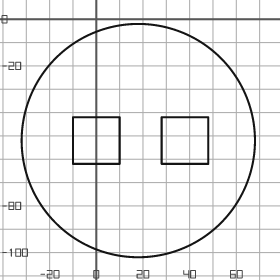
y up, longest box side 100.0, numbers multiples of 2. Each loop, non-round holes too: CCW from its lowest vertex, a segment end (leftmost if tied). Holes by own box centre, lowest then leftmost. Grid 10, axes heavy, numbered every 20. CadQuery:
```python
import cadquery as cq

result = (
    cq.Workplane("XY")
    .moveTo(18.0, -52.0)
    .circle(50.0)
    .moveTo(-10.0, -62.0)
    .lineTo(10.0, -62.0)
    .lineTo(10.0, -42.0)
    .lineTo(-10.0, -42.0)
    .close()
    .moveTo(28.0, -62.0)
    .lineTo(48.0, -62.0)
    .lineTo(48.0, -42.0)
    .lineTo(28.0, -42.0)
    .close()
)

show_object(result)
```